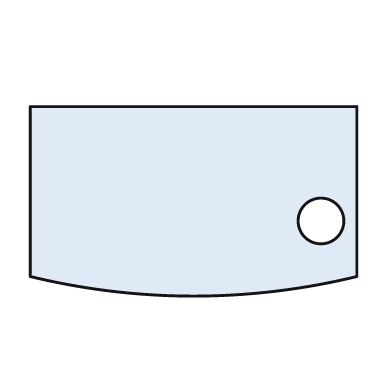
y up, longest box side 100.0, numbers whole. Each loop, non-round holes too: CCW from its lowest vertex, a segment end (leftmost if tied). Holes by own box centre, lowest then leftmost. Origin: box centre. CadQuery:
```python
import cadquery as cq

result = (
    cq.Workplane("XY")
    .moveTo(-50.0, -23.0)
    .threePointArc((0.0, -29.0), (50.0, -23.0))
    .lineTo(50.0, 29.0)
    .lineTo(-50.0, 29.0)
    .close()
    .moveTo(39.0, -6.0)
    .circle(7.0)
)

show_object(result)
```